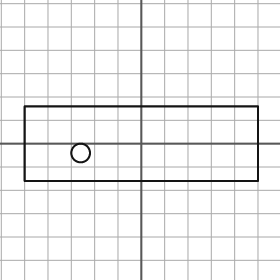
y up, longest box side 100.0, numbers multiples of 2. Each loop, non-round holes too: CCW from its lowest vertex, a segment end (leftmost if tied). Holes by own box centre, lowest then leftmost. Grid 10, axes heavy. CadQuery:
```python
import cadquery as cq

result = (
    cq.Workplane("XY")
    .moveTo(-50.0, -16.0)
    .lineTo(50.0, -16.0)
    .lineTo(50.0, 16.0)
    .lineTo(-50.0, 16.0)
    .close()
    .moveTo(-26.0, -4.0)
    .circle(4.0)
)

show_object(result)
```